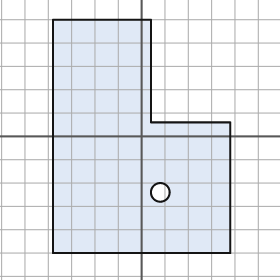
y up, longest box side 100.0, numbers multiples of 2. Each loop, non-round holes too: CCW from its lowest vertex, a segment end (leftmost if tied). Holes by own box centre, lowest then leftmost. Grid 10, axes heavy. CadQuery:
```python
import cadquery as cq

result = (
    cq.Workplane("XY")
    .moveTo(-38.0, -50.0)
    .lineTo(38.0, -50.0)
    .lineTo(38.0, 6.0)
    .lineTo(4.0, 6.0)
    .lineTo(4.0, 50.0)
    .lineTo(-38.0, 50.0)
    .close()
    .moveTo(8.0, -24.0)
    .circle(4.0)
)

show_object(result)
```